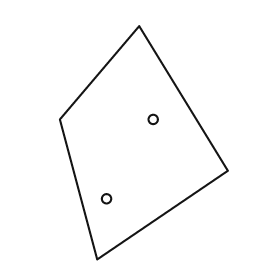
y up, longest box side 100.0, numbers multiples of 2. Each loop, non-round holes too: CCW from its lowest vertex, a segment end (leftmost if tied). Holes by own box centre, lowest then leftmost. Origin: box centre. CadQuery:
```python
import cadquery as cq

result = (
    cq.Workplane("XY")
    .moveTo(-20.0, -50.0)
    .lineTo(36.0, -12.0)
    .lineTo(-2.0, 50.0)
    .lineTo(-36.0, 10.0)
    .close()
    .moveTo(-16.0, -24.0)
    .circle(2.0)
    .moveTo(4.0, 10.0)
    .circle(2.0)
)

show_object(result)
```